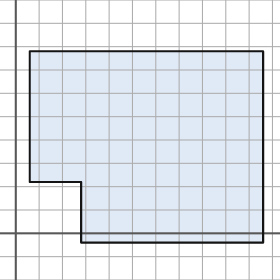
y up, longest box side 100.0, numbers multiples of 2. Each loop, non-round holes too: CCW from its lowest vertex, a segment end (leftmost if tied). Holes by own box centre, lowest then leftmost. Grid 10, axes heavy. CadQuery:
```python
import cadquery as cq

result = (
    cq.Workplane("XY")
    .moveTo(28.0, -4.0)
    .lineTo(106.0, -4.0)
    .lineTo(106.0, 78.0)
    .lineTo(6.0, 78.0)
    .lineTo(6.0, 22.0)
    .lineTo(28.0, 22.0)
    .close()
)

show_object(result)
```